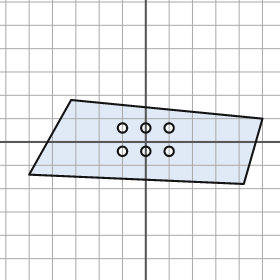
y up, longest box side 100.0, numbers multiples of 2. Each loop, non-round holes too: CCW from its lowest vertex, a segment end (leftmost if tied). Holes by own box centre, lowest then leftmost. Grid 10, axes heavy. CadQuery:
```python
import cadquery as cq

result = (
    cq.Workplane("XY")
    .moveTo(42.0, -18.0)
    .lineTo(50.0, 10.0)
    .lineTo(-32.0, 18.0)
    .lineTo(-50.0, -14.0)
    .close()
    .moveTo(-10.0, -4.0)
    .circle(2.0)
    .moveTo(0.0, -4.0)
    .circle(2.0)
    .moveTo(10.0, -4.0)
    .circle(2.0)
    .moveTo(-10.0, 6.0)
    .circle(2.0)
    .moveTo(0.0, 6.0)
    .circle(2.0)
    .moveTo(10.0, 6.0)
    .circle(2.0)
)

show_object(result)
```